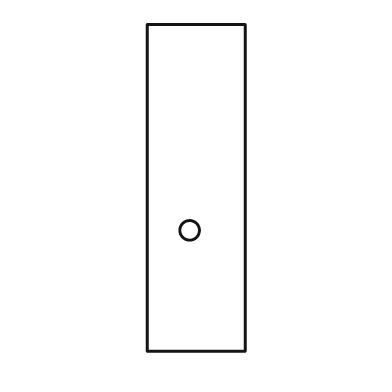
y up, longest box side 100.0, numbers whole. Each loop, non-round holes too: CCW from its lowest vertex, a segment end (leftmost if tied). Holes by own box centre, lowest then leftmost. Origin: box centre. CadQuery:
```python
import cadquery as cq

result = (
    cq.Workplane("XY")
    .moveTo(-15.0, -50.0)
    .lineTo(15.0, -50.0)
    .lineTo(15.0, 50.0)
    .lineTo(-15.0, 50.0)
    .close()
    .moveTo(-2.0, -13.0)
    .circle(3.0)
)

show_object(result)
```